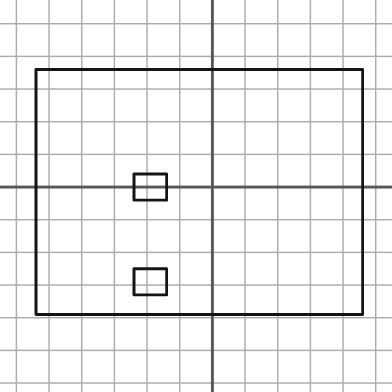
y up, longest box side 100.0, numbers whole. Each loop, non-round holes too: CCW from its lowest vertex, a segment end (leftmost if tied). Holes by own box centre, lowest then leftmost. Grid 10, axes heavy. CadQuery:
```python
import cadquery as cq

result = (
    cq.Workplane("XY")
    .moveTo(-54.0, -39.0)
    .lineTo(46.0, -39.0)
    .lineTo(46.0, 36.0)
    .lineTo(-54.0, 36.0)
    .close()
    .moveTo(-24.0, -33.0)
    .lineTo(-14.0, -33.0)
    .lineTo(-14.0, -25.0)
    .lineTo(-24.0, -25.0)
    .close()
    .moveTo(-24.0, -4.0)
    .lineTo(-14.0, -4.0)
    .lineTo(-14.0, 4.0)
    .lineTo(-24.0, 4.0)
    .close()
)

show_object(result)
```